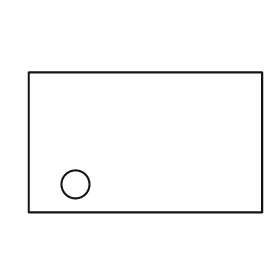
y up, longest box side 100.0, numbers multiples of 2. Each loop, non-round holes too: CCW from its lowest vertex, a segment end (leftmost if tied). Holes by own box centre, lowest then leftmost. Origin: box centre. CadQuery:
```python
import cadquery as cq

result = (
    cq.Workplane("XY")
    .moveTo(-50.0, -30.0)
    .lineTo(50.0, -30.0)
    .lineTo(50.0, 30.0)
    .lineTo(-50.0, 30.0)
    .close()
    .moveTo(-30.0, -18.0)
    .circle(6.0)
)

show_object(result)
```